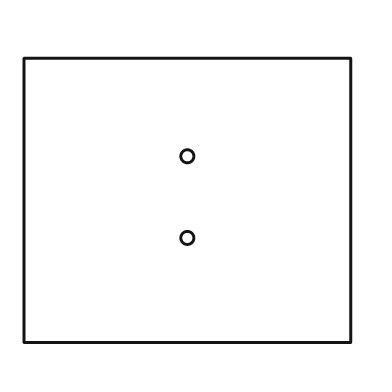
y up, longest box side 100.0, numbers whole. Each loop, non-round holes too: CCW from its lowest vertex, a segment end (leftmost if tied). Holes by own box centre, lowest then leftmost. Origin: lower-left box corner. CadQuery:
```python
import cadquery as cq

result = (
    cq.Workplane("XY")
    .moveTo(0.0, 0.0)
    .lineTo(100.0, 0.0)
    .lineTo(100.0, 87.0)
    .lineTo(0.0, 87.0)
    .close()
    .moveTo(50.0, 32.0)
    .circle(2.0)
    .moveTo(50.0, 57.0)
    .circle(2.0)
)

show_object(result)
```